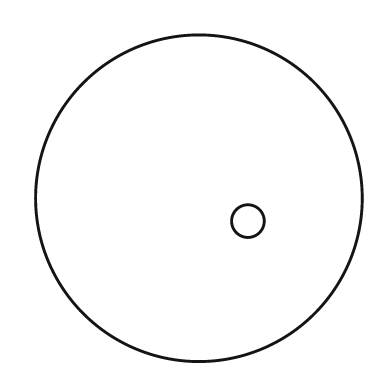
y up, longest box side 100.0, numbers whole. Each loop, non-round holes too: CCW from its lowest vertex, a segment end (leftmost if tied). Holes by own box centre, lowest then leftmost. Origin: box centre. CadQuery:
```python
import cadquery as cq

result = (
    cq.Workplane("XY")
    .moveTo(0.0, 0.0)
    .circle(50.0)
    .moveTo(15.0, -7.0)
    .circle(5.0)
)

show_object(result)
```